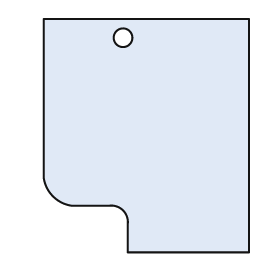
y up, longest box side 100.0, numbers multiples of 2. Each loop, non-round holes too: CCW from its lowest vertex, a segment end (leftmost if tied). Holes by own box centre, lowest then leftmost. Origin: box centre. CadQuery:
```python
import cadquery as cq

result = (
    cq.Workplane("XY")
    .moveTo(-8.0, -50.0)
    .lineTo(44.0, -50.0)
    .lineTo(44.0, 50.0)
    .lineTo(-44.0, 50.0)
    .lineTo(-44.0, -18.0)
    .threePointArc((-40.0, -26.0), (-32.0, -30.0))
    .lineTo(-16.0, -30.0)
    .threePointArc((-10.0, -32.0), (-8.0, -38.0))
    .close()
    .moveTo(-10.0, 42.0)
    .circle(4.0)
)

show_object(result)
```